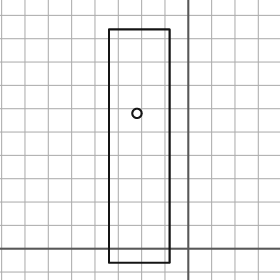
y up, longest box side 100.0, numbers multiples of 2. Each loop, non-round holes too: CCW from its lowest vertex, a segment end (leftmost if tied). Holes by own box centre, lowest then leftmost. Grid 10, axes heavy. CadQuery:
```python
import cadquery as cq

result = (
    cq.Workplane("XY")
    .moveTo(-34.0, -6.0)
    .lineTo(-8.0, -6.0)
    .lineTo(-8.0, 94.0)
    .lineTo(-34.0, 94.0)
    .close()
    .moveTo(-22.0, 58.0)
    .circle(2.0)
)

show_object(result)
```